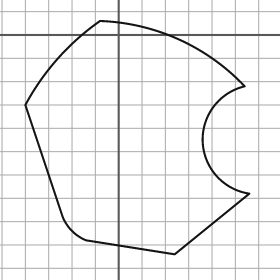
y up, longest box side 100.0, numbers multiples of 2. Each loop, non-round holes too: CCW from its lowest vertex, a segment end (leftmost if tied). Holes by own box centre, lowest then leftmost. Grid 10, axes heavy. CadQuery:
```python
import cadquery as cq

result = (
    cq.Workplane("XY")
    .moveTo(24.0, -94.0)
    .lineTo(56.0, -68.0)
    .threePointArc((36.0, -46.0), (54.0, -22.0))
    .threePointArc((26.0, -2.0), (-8.0, 6.0))
    .threePointArc((-26.0, -10.0), (-40.0, -30.0))
    .lineTo(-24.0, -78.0)
    .threePointArc((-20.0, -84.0), (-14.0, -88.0))
    .close()
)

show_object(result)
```